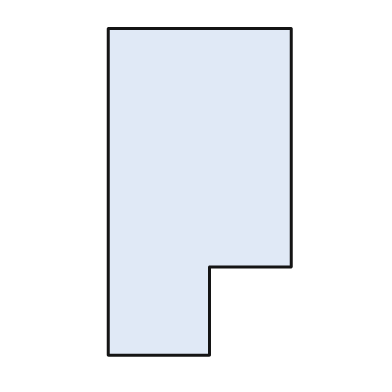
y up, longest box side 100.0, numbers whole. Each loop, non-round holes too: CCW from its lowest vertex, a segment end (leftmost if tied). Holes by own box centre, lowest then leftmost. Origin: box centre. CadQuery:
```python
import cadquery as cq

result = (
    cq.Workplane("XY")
    .moveTo(-28.0, -50.0)
    .lineTo(3.0, -50.0)
    .lineTo(3.0, -23.0)
    .lineTo(28.0, -23.0)
    .lineTo(28.0, 50.0)
    .lineTo(-28.0, 50.0)
    .close()
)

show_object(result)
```